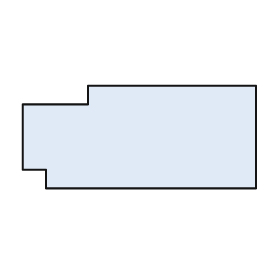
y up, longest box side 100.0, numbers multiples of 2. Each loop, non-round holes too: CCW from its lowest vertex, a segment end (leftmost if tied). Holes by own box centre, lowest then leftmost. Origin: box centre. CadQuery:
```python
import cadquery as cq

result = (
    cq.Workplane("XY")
    .moveTo(-40.0, -22.0)
    .lineTo(50.0, -22.0)
    .lineTo(50.0, 22.0)
    .lineTo(-22.0, 22.0)
    .lineTo(-22.0, 14.0)
    .lineTo(-50.0, 14.0)
    .lineTo(-50.0, -14.0)
    .lineTo(-40.0, -14.0)
    .close()
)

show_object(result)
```